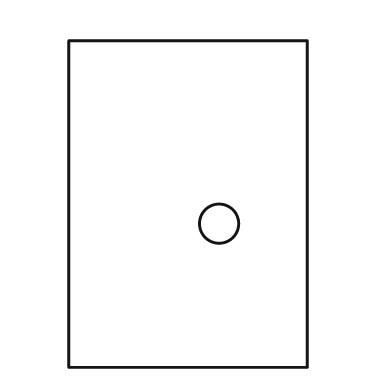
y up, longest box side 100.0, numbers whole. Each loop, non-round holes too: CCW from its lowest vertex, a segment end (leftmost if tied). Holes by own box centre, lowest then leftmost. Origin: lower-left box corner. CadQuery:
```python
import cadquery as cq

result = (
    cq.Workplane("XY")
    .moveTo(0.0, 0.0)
    .lineTo(73.0, 0.0)
    .lineTo(73.0, 100.0)
    .lineTo(0.0, 100.0)
    .close()
    .moveTo(46.0, 44.0)
    .circle(6.0)
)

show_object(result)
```